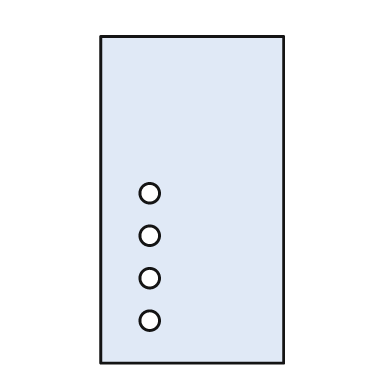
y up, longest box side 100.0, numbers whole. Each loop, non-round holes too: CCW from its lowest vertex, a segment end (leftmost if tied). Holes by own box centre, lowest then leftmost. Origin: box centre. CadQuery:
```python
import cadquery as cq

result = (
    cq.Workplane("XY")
    .moveTo(-28.0, -50.0)
    .lineTo(28.0, -50.0)
    .lineTo(28.0, 50.0)
    .lineTo(-28.0, 50.0)
    .close()
    .moveTo(-13.0, -37.0)
    .circle(3.0)
    .moveTo(-13.0, -24.0)
    .circle(3.0)
    .moveTo(-13.0, -11.0)
    .circle(3.0)
    .moveTo(-13.0, 2.0)
    .circle(3.0)
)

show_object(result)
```